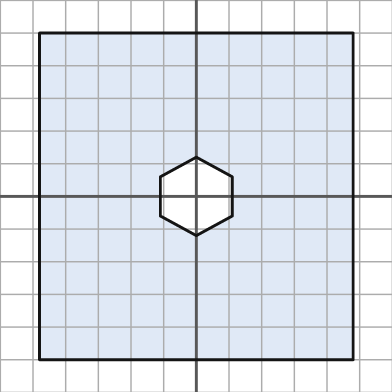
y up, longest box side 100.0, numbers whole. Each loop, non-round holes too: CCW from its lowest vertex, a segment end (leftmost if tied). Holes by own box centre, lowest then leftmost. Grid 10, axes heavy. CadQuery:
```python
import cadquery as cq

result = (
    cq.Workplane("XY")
    .moveTo(-48.0, -50.0)
    .lineTo(48.0, -50.0)
    .lineTo(48.0, 50.0)
    .lineTo(-48.0, 50.0)
    .close()
    .moveTo(0.0, -12.0)
    .lineTo(11.0, -6.0)
    .lineTo(11.0, 6.0)
    .lineTo(0.0, 12.0)
    .lineTo(-11.0, 6.0)
    .lineTo(-11.0, -6.0)
    .close()
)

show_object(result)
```